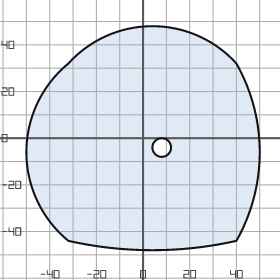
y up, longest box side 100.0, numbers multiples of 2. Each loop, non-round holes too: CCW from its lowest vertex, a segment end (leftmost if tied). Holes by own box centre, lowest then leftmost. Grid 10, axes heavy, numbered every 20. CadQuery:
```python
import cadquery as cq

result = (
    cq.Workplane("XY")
    .moveTo(-32.0, -44.0)
    .threePointArc((4.0, -48.0), (40.0, -44.0))
    .threePointArc((50.0, -6.0), (40.0, 32.0))
    .threePointArc((4.0, 48.0), (-32.0, 32.0))
    .threePointArc((-50.0, -6.0), (-32.0, -44.0))
    .close()
    .moveTo(8.0, -4.0)
    .circle(4.0)
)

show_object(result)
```